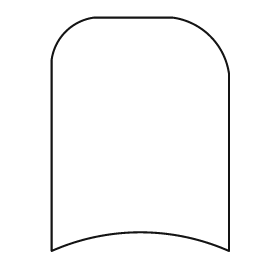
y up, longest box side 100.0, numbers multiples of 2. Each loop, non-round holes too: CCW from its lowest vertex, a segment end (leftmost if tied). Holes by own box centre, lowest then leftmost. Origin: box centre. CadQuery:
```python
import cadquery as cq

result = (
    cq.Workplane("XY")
    .moveTo(-38.0, -50.0)
    .threePointArc((0.0, -42.0), (38.0, -50.0))
    .lineTo(38.0, 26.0)
    .threePointArc((30.0, 42.0), (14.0, 50.0))
    .lineTo(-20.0, 50.0)
    .threePointArc((-32.0, 44.0), (-38.0, 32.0))
    .close()
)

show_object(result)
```